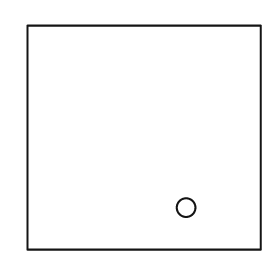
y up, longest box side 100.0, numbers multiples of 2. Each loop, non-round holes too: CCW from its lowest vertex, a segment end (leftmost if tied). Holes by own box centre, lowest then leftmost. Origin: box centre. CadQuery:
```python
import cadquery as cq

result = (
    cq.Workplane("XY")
    .moveTo(-50.0, -48.0)
    .lineTo(50.0, -48.0)
    .lineTo(50.0, 48.0)
    .lineTo(-50.0, 48.0)
    .close()
    .moveTo(18.0, -30.0)
    .circle(4.0)
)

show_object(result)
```